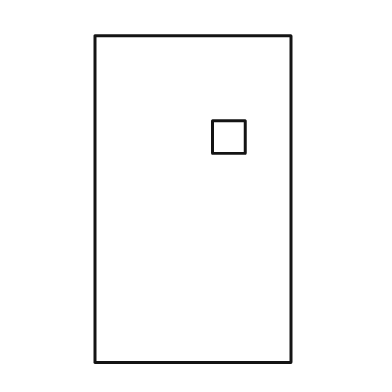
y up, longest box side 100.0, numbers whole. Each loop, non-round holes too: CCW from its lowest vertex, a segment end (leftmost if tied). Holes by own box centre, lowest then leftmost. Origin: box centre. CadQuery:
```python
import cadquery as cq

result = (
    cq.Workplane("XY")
    .moveTo(-30.0, -50.0)
    .lineTo(30.0, -50.0)
    .lineTo(30.0, 50.0)
    .lineTo(-30.0, 50.0)
    .close()
    .moveTo(6.0, 14.0)
    .lineTo(16.0, 14.0)
    .lineTo(16.0, 24.0)
    .lineTo(6.0, 24.0)
    .close()
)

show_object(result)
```